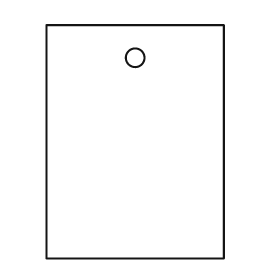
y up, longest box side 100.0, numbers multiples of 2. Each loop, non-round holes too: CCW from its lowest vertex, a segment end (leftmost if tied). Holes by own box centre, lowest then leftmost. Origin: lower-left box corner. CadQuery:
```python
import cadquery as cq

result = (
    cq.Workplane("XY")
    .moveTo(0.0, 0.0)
    .lineTo(76.0, 0.0)
    .lineTo(76.0, 100.0)
    .lineTo(0.0, 100.0)
    .close()
    .moveTo(38.0, 86.0)
    .circle(4.0)
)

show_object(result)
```